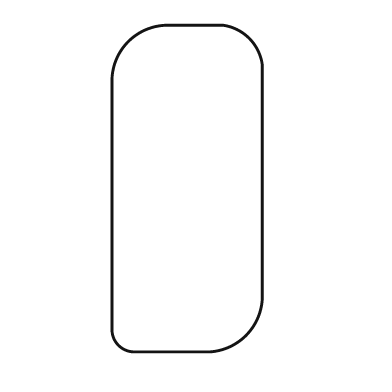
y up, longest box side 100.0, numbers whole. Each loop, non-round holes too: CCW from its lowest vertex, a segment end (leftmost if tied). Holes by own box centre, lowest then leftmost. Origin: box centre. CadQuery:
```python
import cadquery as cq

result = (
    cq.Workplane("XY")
    .moveTo(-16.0, -50.0)
    .lineTo(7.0, -50.0)
    .threePointArc((18.0, -45.0), (23.0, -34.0))
    .lineTo(23.0, 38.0)
    .threePointArc((19.0, 46.0), (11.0, 50.0))
    .lineTo(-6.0, 50.0)
    .threePointArc((-18.0, 45.0), (-23.0, 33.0))
    .lineTo(-23.0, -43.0)
    .threePointArc((-21.0, -48.0), (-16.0, -50.0))
    .close()
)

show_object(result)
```